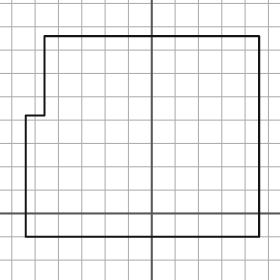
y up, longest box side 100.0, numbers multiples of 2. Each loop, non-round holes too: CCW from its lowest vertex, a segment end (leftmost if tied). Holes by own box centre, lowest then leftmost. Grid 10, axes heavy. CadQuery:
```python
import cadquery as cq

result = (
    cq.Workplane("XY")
    .moveTo(-54.0, -10.0)
    .lineTo(46.0, -10.0)
    .lineTo(46.0, 76.0)
    .lineTo(-46.0, 76.0)
    .lineTo(-46.0, 42.0)
    .lineTo(-54.0, 42.0)
    .close()
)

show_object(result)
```